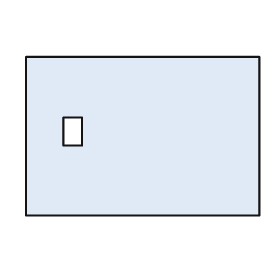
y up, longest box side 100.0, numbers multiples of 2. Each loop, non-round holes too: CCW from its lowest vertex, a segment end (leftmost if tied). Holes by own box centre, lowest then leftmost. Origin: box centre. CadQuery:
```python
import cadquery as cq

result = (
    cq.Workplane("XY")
    .moveTo(-50.0, -34.0)
    .lineTo(50.0, -34.0)
    .lineTo(50.0, 34.0)
    .lineTo(-50.0, 34.0)
    .close()
    .moveTo(-34.0, -4.0)
    .lineTo(-26.0, -4.0)
    .lineTo(-26.0, 8.0)
    .lineTo(-34.0, 8.0)
    .close()
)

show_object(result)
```